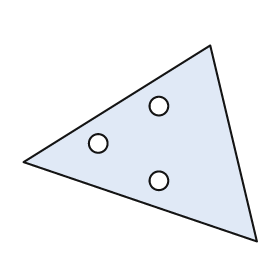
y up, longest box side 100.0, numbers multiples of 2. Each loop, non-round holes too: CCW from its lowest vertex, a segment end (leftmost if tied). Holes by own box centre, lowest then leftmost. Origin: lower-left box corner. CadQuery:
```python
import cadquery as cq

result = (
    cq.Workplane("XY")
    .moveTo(100.0, 0.0)
    .lineTo(80.0, 84.0)
    .lineTo(0.0, 34.0)
    .close()
    .moveTo(58.0, 26.0)
    .circle(4.0)
    .moveTo(32.0, 42.0)
    .circle(4.0)
    .moveTo(58.0, 58.0)
    .circle(4.0)
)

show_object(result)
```